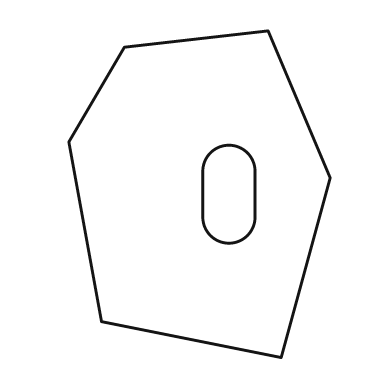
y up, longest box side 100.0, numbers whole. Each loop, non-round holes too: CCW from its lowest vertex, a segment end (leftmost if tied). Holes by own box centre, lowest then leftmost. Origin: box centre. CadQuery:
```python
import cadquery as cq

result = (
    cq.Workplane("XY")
    .moveTo(25.0, -50.0)
    .lineTo(40.0, 5.0)
    .lineTo(21.0, 50.0)
    .lineTo(-23.0, 45.0)
    .lineTo(-40.0, 16.0)
    .lineTo(-30.0, -39.0)
    .close()
    .moveTo(1.0, -7.0)
    .threePointArc((9.0, -15.0), (17.0, -7.0))
    .lineTo(17.0, 7.0)
    .threePointArc((9.0, 15.0), (1.0, 7.0))
    .close()
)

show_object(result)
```